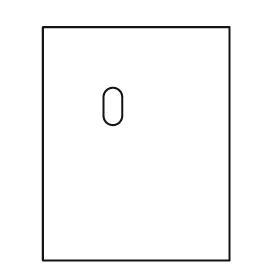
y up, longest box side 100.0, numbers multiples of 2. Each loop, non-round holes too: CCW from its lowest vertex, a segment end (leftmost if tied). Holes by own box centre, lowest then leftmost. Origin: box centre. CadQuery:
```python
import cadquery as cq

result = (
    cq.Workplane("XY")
    .moveTo(-40.0, -50.0)
    .lineTo(40.0, -50.0)
    .lineTo(40.0, 50.0)
    .lineTo(-40.0, 50.0)
    .close()
    .moveTo(-14.0, 12.0)
    .threePointArc((-10.0, 8.0), (-6.0, 12.0))
    .lineTo(-6.0, 20.0)
    .threePointArc((-10.0, 24.0), (-14.0, 20.0))
    .close()
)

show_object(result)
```